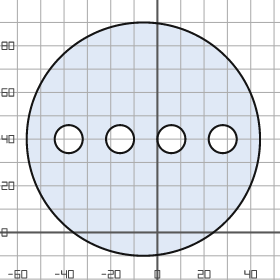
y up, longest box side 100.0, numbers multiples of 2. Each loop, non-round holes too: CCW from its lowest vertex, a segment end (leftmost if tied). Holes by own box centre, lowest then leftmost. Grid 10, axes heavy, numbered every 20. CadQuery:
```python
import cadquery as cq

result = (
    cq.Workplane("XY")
    .moveTo(-6.0, 40.0)
    .circle(50.0)
    .moveTo(-38.0, 40.0)
    .circle(6.0)
    .moveTo(-16.0, 40.0)
    .circle(6.0)
    .moveTo(6.0, 40.0)
    .circle(6.0)
    .moveTo(28.0, 40.0)
    .circle(6.0)
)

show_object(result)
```